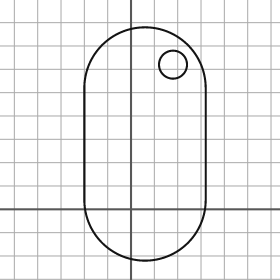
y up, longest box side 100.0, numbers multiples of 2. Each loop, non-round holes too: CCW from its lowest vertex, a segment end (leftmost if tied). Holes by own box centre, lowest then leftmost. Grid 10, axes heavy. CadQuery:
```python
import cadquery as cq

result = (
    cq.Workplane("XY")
    .moveTo(-20.0, 4.0)
    .threePointArc((6.0, -22.0), (32.0, 4.0))
    .lineTo(32.0, 52.0)
    .threePointArc((6.0, 78.0), (-20.0, 52.0))
    .close()
    .moveTo(18.0, 62.0)
    .circle(6.0)
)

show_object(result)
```